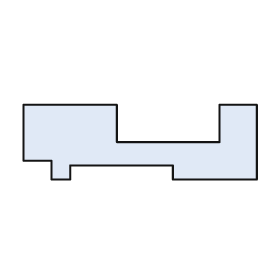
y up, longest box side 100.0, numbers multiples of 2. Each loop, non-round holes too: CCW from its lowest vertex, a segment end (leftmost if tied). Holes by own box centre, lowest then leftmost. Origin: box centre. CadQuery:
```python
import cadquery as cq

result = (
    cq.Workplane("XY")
    .moveTo(-38.0, -16.0)
    .lineTo(-30.0, -16.0)
    .lineTo(-30.0, -10.0)
    .lineTo(14.0, -10.0)
    .lineTo(14.0, -16.0)
    .lineTo(50.0, -16.0)
    .lineTo(50.0, 16.0)
    .lineTo(34.0, 16.0)
    .lineTo(34.0, 0.0)
    .lineTo(-10.0, 0.0)
    .lineTo(-10.0, 16.0)
    .lineTo(-50.0, 16.0)
    .lineTo(-50.0, -8.0)
    .lineTo(-38.0, -8.0)
    .close()
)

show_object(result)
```